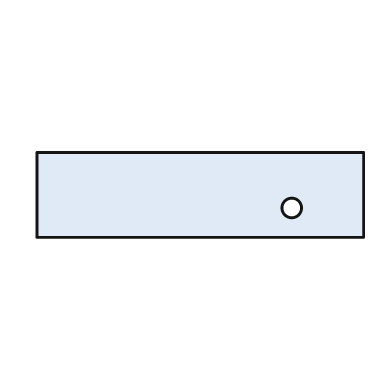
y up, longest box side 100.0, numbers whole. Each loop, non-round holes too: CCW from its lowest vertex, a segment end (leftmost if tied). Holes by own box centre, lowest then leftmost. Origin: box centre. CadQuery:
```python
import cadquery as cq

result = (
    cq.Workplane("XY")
    .moveTo(-50.0, -13.0)
    .lineTo(50.0, -13.0)
    .lineTo(50.0, 13.0)
    .lineTo(-50.0, 13.0)
    .close()
    .moveTo(28.0, -4.0)
    .circle(3.0)
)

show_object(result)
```